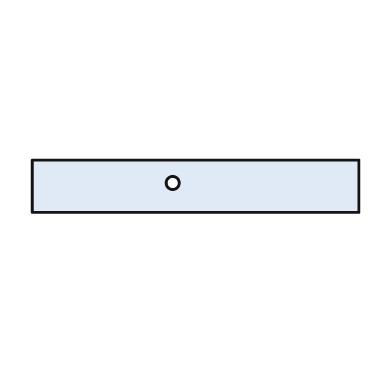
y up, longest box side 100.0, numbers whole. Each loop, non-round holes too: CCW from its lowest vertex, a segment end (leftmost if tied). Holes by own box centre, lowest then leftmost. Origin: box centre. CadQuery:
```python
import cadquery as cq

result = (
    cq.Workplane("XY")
    .moveTo(-50.0, -8.0)
    .lineTo(50.0, -8.0)
    .lineTo(50.0, 8.0)
    .lineTo(-50.0, 8.0)
    .close()
    .moveTo(-7.0, 1.0)
    .circle(2.0)
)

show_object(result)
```